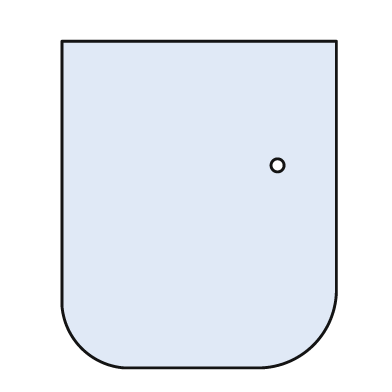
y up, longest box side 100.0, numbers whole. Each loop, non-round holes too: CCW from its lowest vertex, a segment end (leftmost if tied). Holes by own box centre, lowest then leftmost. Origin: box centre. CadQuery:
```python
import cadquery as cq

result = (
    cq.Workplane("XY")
    .moveTo(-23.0, -50.0)
    .lineTo(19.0, -50.0)
    .threePointArc((35.0, -43.0), (42.0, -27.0))
    .lineTo(42.0, 50.0)
    .lineTo(-42.0, 50.0)
    .lineTo(-42.0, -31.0)
    .threePointArc((-36.0, -44.0), (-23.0, -50.0))
    .close()
    .moveTo(24.0, 12.0)
    .circle(2.0)
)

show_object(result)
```